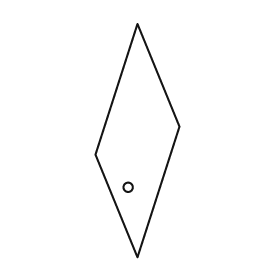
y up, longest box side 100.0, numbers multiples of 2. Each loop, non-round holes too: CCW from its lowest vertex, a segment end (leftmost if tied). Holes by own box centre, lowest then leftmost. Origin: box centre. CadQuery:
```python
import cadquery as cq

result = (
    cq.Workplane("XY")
    .moveTo(0.0, -50.0)
    .lineTo(18.0, 6.0)
    .lineTo(0.0, 50.0)
    .lineTo(-18.0, -6.0)
    .close()
    .moveTo(-4.0, -20.0)
    .circle(2.0)
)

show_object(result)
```